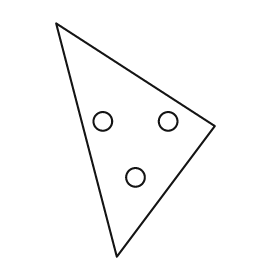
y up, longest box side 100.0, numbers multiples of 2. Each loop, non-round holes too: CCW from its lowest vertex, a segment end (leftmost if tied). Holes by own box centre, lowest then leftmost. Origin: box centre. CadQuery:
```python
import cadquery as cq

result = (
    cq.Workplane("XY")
    .moveTo(-8.0, -50.0)
    .lineTo(34.0, 6.0)
    .lineTo(-34.0, 50.0)
    .close()
    .moveTo(0.0, -16.0)
    .circle(4.0)
    .moveTo(-14.0, 8.0)
    .circle(4.0)
    .moveTo(14.0, 8.0)
    .circle(4.0)
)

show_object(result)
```